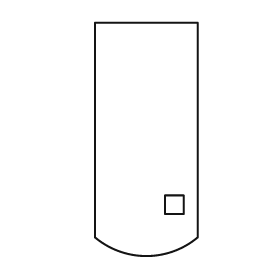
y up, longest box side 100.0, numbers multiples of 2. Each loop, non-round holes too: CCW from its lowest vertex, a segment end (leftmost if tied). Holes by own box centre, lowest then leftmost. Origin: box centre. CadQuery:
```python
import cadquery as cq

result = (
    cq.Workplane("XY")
    .moveTo(-22.0, -42.0)
    .threePointArc((0.0, -50.0), (22.0, -42.0))
    .lineTo(22.0, 50.0)
    .lineTo(-22.0, 50.0)
    .close()
    .moveTo(8.0, -32.0)
    .lineTo(16.0, -32.0)
    .lineTo(16.0, -24.0)
    .lineTo(8.0, -24.0)
    .close()
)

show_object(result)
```